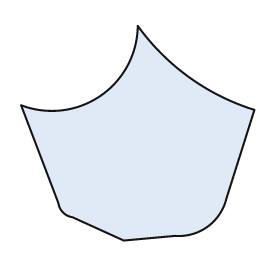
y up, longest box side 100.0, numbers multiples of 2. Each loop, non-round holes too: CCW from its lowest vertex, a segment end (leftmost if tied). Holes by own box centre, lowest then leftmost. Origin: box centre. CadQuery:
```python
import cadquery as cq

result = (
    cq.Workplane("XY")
    .moveTo(-6.0, -46.0)
    .lineTo(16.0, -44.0)
    .threePointArc((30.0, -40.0), (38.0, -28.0))
    .lineTo(50.0, 10.0)
    .threePointArc((22.0, 24.0), (0.0, 46.0))
    .threePointArc((-16.0, 16.0), (-50.0, 12.0))
    .lineTo(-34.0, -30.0)
    .threePointArc((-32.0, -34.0), (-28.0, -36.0))
    .close()
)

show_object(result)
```